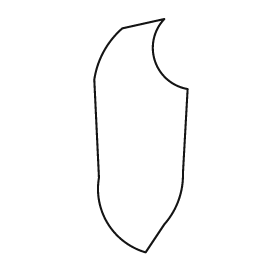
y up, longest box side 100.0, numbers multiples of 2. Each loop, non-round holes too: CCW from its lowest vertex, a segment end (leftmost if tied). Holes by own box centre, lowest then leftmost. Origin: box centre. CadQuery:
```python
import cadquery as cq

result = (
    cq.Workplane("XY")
    .moveTo(2.0, -50.0)
    .lineTo(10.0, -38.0)
    .threePointArc((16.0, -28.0), (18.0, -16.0))
    .lineTo(20.0, 20.0)
    .threePointArc((6.0, 32.0), (10.0, 50.0))
    .lineTo(-8.0, 46.0)
    .threePointArc((-16.0, 36.0), (-20.0, 24.0))
    .lineTo(-18.0, -18.0)
    .threePointArc((-14.0, -38.0), (2.0, -50.0))
    .close()
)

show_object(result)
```